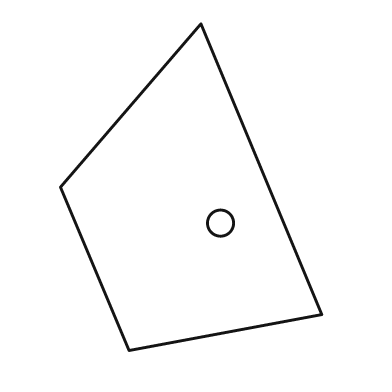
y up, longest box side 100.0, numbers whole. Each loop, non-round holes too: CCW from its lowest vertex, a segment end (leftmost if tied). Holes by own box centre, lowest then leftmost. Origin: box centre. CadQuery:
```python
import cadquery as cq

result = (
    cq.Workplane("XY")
    .moveTo(-19.0, -50.0)
    .lineTo(40.0, -39.0)
    .lineTo(3.0, 50.0)
    .lineTo(-40.0, 0.0)
    .close()
    .moveTo(9.0, -11.0)
    .circle(4.0)
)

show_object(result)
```